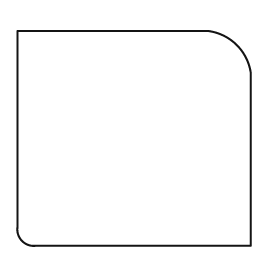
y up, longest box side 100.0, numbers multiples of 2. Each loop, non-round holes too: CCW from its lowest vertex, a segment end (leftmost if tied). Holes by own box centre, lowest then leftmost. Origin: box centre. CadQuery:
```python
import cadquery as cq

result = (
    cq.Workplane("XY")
    .moveTo(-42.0, -46.0)
    .lineTo(50.0, -46.0)
    .lineTo(50.0, 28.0)
    .threePointArc((44.0, 40.0), (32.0, 46.0))
    .lineTo(-50.0, 46.0)
    .lineTo(-50.0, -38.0)
    .threePointArc((-48.0, -44.0), (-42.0, -46.0))
    .close()
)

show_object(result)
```